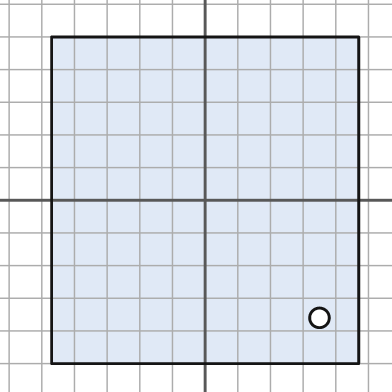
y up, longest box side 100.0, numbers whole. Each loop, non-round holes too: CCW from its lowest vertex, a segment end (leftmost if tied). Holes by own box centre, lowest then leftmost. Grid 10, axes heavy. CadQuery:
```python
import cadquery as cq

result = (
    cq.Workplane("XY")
    .moveTo(-47.0, -50.0)
    .lineTo(47.0, -50.0)
    .lineTo(47.0, 50.0)
    .lineTo(-47.0, 50.0)
    .close()
    .moveTo(35.0, -36.0)
    .circle(3.0)
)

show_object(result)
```